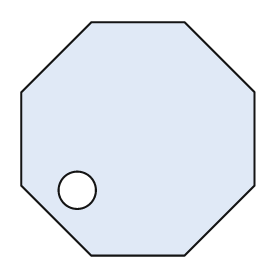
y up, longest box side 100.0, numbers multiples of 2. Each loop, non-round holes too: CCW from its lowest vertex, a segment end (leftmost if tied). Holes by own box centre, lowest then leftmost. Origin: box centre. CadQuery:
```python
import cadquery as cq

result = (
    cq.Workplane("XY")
    .moveTo(-20.0, -50.0)
    .lineTo(20.0, -50.0)
    .lineTo(50.0, -20.0)
    .lineTo(50.0, 20.0)
    .lineTo(20.0, 50.0)
    .lineTo(-20.0, 50.0)
    .lineTo(-50.0, 20.0)
    .lineTo(-50.0, -20.0)
    .close()
    .moveTo(-26.0, -22.0)
    .circle(8.0)
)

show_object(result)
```